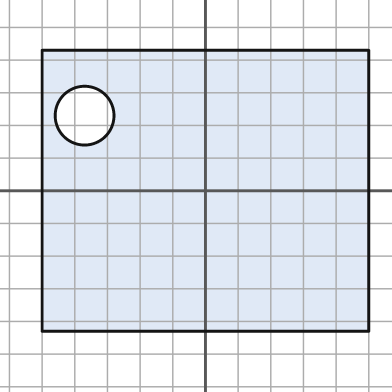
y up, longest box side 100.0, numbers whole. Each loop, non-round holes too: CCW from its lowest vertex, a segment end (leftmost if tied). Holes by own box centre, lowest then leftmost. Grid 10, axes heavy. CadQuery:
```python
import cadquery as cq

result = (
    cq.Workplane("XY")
    .moveTo(-50.0, -43.0)
    .lineTo(50.0, -43.0)
    .lineTo(50.0, 43.0)
    .lineTo(-50.0, 43.0)
    .close()
    .moveTo(-37.0, 23.0)
    .circle(9.0)
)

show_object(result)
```